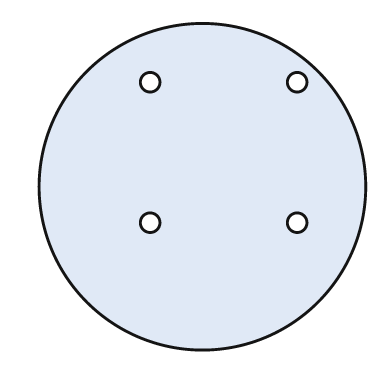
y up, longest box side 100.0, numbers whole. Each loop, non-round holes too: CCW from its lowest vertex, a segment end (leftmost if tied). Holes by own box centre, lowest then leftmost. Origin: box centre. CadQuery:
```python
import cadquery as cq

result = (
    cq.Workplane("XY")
    .moveTo(0.0, 0.0)
    .circle(50.0)
    .moveTo(-16.0, -11.0)
    .circle(3.0)
    .moveTo(29.0, -11.0)
    .circle(3.0)
    .moveTo(-16.0, 32.0)
    .circle(3.0)
    .moveTo(29.0, 32.0)
    .circle(3.0)
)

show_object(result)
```